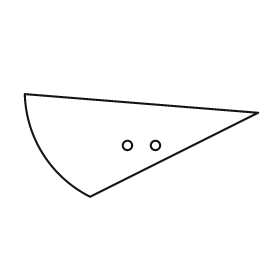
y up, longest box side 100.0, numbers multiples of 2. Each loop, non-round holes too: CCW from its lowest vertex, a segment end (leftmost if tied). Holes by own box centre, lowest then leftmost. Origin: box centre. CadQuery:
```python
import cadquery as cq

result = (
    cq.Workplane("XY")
    .moveTo(-22.0, -22.0)
    .lineTo(50.0, 14.0)
    .lineTo(-50.0, 22.0)
    .threePointArc((-42.0, -4.0), (-22.0, -22.0))
    .close()
    .moveTo(-6.0, 0.0)
    .circle(2.0)
    .moveTo(6.0, 0.0)
    .circle(2.0)
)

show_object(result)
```